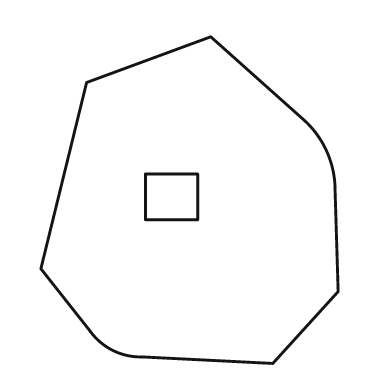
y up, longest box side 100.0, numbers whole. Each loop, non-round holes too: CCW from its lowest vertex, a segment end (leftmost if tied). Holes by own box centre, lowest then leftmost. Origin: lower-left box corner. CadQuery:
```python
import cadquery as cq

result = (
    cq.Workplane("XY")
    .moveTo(71.0, 0.0)
    .lineTo(91.0, 22.0)
    .lineTo(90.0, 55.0)
    .threePointArc((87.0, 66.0), (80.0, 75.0))
    .lineTo(52.0, 100.0)
    .lineTo(14.0, 86.0)
    .lineTo(0.0, 29.0)
    .lineTo(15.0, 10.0)
    .threePointArc((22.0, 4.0), (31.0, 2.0))
    .close()
    .moveTo(32.0, 44.0)
    .lineTo(48.0, 44.0)
    .lineTo(48.0, 58.0)
    .lineTo(32.0, 58.0)
    .close()
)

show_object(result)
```